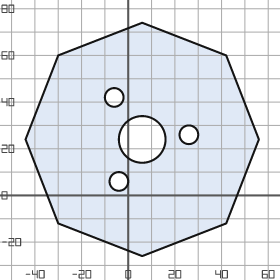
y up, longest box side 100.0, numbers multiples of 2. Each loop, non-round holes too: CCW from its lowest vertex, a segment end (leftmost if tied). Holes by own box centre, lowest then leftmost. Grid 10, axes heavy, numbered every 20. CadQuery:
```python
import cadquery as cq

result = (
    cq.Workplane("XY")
    .moveTo(6.0, -26.0)
    .lineTo(42.0, -12.0)
    .lineTo(56.0, 24.0)
    .lineTo(42.0, 60.0)
    .lineTo(6.0, 74.0)
    .lineTo(-30.0, 60.0)
    .lineTo(-44.0, 24.0)
    .lineTo(-30.0, -12.0)
    .close()
    .moveTo(-4.0, 6.0)
    .circle(4.0)
    .moveTo(6.0, 24.0)
    .circle(10.0)
    .moveTo(26.0, 26.0)
    .circle(4.0)
    .moveTo(-6.0, 42.0)
    .circle(4.0)
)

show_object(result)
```